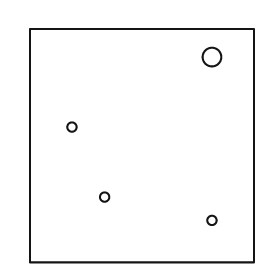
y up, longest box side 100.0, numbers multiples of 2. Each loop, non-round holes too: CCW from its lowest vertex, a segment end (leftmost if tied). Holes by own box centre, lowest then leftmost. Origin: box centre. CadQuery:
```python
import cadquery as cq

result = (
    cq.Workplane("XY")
    .moveTo(-48.0, -50.0)
    .lineTo(48.0, -50.0)
    .lineTo(48.0, 50.0)
    .lineTo(-48.0, 50.0)
    .close()
    .moveTo(30.0, -32.0)
    .circle(2.0)
    .moveTo(-16.0, -22.0)
    .circle(2.0)
    .moveTo(-30.0, 8.0)
    .circle(2.0)
    .moveTo(30.0, 38.0)
    .circle(4.0)
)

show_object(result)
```